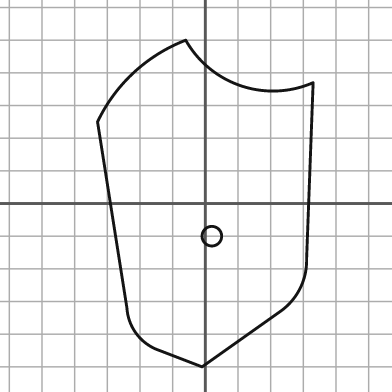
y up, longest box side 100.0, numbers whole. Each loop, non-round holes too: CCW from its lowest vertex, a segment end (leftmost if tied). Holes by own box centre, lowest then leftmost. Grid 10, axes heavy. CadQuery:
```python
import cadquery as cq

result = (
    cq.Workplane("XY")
    .moveTo(-1.0, -50.0)
    .lineTo(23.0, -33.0)
    .threePointArc((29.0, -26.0), (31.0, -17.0))
    .lineTo(33.0, 37.0)
    .threePointArc((11.0, 36.0), (-6.0, 50.0))
    .threePointArc((-22.0, 40.0), (-33.0, 25.0))
    .lineTo(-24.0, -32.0)
    .threePointArc((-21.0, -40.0), (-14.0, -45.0))
    .close()
    .moveTo(2.0, -10.0)
    .circle(3.0)
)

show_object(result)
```